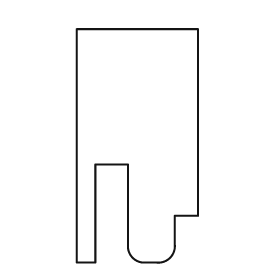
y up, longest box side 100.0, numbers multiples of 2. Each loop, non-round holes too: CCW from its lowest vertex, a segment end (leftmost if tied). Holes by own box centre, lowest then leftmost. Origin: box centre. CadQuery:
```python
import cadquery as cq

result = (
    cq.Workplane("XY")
    .moveTo(-26.0, -50.0)
    .lineTo(-18.0, -50.0)
    .lineTo(-18.0, -8.0)
    .lineTo(-4.0, -8.0)
    .lineTo(-4.0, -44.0)
    .threePointArc((-2.0, -48.0), (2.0, -50.0))
    .lineTo(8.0, -50.0)
    .threePointArc((14.0, -48.0), (16.0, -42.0))
    .lineTo(16.0, -30.0)
    .lineTo(26.0, -30.0)
    .lineTo(26.0, 50.0)
    .lineTo(-26.0, 50.0)
    .close()
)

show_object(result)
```